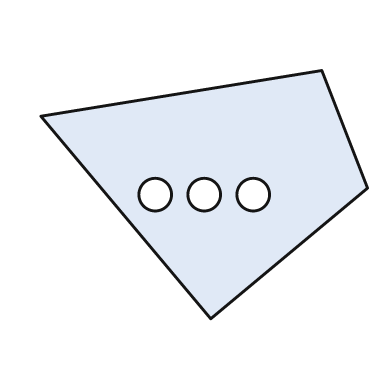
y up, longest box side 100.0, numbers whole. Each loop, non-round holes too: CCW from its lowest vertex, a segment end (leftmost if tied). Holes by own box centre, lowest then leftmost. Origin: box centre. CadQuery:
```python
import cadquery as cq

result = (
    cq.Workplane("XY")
    .moveTo(2.0, -38.0)
    .lineTo(50.0, 2.0)
    .lineTo(36.0, 38.0)
    .lineTo(-50.0, 24.0)
    .close()
    .moveTo(-15.0, 0.0)
    .circle(5.0)
    .moveTo(0.0, 0.0)
    .circle(5.0)
    .moveTo(15.0, 0.0)
    .circle(5.0)
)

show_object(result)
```